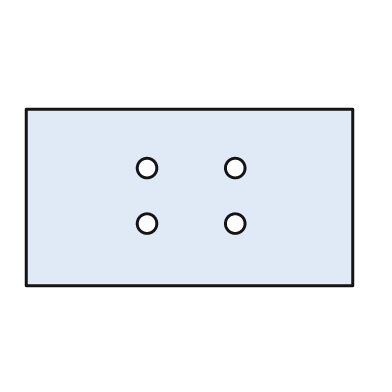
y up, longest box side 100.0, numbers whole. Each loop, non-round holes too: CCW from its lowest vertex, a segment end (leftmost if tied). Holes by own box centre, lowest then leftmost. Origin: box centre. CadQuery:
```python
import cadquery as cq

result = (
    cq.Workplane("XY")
    .moveTo(-50.0, -27.0)
    .lineTo(50.0, -27.0)
    .lineTo(50.0, 27.0)
    .lineTo(-50.0, 27.0)
    .close()
    .moveTo(-13.0, -8.0)
    .circle(3.0)
    .moveTo(14.0, -8.0)
    .circle(3.0)
    .moveTo(-13.0, 9.0)
    .circle(3.0)
    .moveTo(14.0, 9.0)
    .circle(3.0)
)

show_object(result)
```